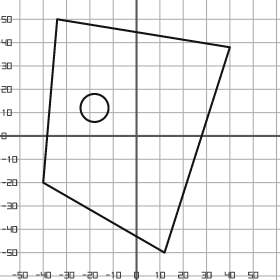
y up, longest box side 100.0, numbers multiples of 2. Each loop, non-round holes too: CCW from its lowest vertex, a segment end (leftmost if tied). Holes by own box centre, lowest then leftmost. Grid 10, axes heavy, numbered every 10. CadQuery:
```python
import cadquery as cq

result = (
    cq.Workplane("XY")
    .moveTo(12.0, -50.0)
    .lineTo(40.0, 38.0)
    .lineTo(-34.0, 50.0)
    .lineTo(-40.0, -20.0)
    .close()
    .moveTo(-18.0, 12.0)
    .circle(6.0)
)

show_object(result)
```